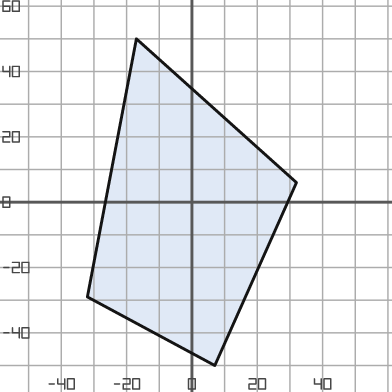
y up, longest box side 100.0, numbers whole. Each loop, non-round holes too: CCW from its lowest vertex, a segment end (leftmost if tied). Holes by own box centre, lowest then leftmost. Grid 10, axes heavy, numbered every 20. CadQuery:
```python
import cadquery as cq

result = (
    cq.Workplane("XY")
    .moveTo(7.0, -50.0)
    .lineTo(32.0, 6.0)
    .lineTo(-17.0, 50.0)
    .lineTo(-32.0, -29.0)
    .close()
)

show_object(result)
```